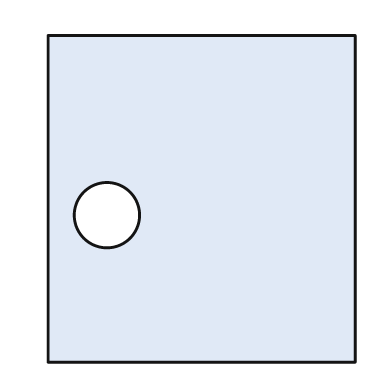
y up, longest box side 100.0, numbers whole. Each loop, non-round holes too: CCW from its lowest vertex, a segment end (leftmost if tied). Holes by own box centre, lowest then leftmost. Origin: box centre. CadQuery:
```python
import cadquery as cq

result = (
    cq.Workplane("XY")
    .moveTo(-47.0, -50.0)
    .lineTo(47.0, -50.0)
    .lineTo(47.0, 50.0)
    .lineTo(-47.0, 50.0)
    .close()
    .moveTo(-29.0, -5.0)
    .circle(10.0)
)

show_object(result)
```